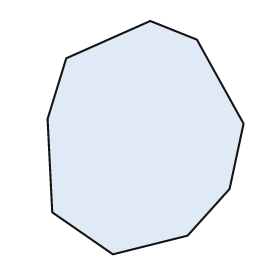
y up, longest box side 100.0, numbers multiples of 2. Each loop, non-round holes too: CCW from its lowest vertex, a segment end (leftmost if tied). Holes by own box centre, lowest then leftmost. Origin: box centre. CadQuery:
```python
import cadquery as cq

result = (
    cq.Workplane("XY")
    .moveTo(-14.0, -50.0)
    .lineTo(18.0, -42.0)
    .lineTo(36.0, -22.0)
    .lineTo(42.0, 6.0)
    .lineTo(22.0, 42.0)
    .lineTo(2.0, 50.0)
    .lineTo(-34.0, 34.0)
    .lineTo(-42.0, 8.0)
    .lineTo(-40.0, -32.0)
    .close()
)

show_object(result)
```